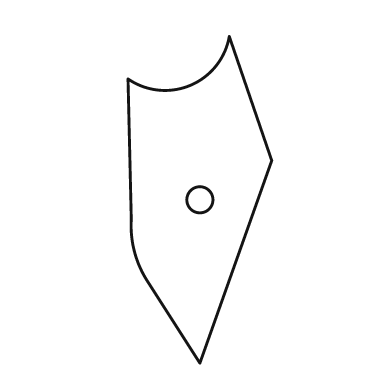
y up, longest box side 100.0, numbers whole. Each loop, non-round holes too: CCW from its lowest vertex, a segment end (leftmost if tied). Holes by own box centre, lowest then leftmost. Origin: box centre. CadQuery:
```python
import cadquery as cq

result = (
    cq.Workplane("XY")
    .moveTo(0.0, -50.0)
    .lineTo(22.0, 12.0)
    .lineTo(9.0, 50.0)
    .threePointArc((-3.0, 35.0), (-22.0, 37.0))
    .lineTo(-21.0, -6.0)
    .threePointArc((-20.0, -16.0), (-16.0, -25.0))
    .close()
    .moveTo(0.0, 0.0)
    .circle(4.0)
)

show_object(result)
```